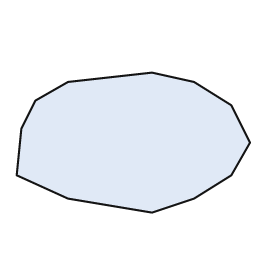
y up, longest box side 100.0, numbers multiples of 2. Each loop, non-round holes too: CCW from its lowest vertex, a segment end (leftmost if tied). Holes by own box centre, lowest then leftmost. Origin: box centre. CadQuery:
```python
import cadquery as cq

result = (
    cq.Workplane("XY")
    .moveTo(8.0, -30.0)
    .lineTo(26.0, -24.0)
    .lineTo(42.0, -14.0)
    .lineTo(50.0, 0.0)
    .lineTo(42.0, 16.0)
    .lineTo(26.0, 26.0)
    .lineTo(8.0, 30.0)
    .lineTo(-28.0, 26.0)
    .lineTo(-42.0, 18.0)
    .lineTo(-48.0, 6.0)
    .lineTo(-50.0, -14.0)
    .lineTo(-28.0, -24.0)
    .close()
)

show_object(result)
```